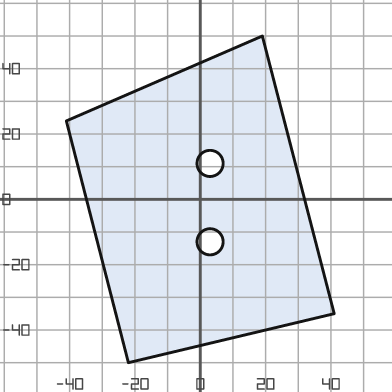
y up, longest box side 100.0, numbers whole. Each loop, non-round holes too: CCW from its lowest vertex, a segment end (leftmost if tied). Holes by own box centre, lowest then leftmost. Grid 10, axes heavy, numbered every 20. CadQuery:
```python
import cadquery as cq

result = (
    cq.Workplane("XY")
    .moveTo(-22.0, -50.0)
    .lineTo(41.0, -35.0)
    .lineTo(19.0, 50.0)
    .lineTo(-41.0, 24.0)
    .close()
    .moveTo(3.0, -13.0)
    .circle(4.0)
    .moveTo(3.0, 11.0)
    .circle(4.0)
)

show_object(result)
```